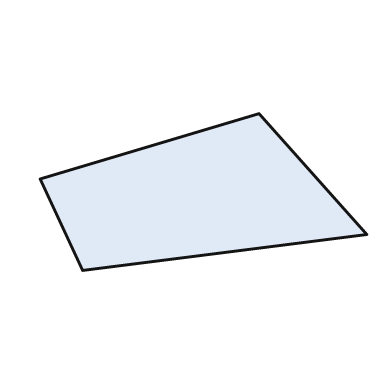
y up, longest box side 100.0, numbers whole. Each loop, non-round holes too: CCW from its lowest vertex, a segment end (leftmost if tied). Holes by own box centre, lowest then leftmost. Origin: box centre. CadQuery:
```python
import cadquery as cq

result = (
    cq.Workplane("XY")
    .moveTo(-37.0, -24.0)
    .lineTo(50.0, -13.0)
    .lineTo(17.0, 24.0)
    .lineTo(-50.0, 4.0)
    .close()
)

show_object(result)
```